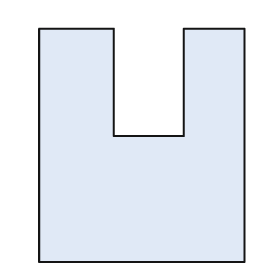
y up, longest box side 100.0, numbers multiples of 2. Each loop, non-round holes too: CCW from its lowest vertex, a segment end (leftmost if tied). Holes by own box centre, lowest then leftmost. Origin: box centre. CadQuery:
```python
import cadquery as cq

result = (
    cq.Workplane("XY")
    .moveTo(-44.0, -50.0)
    .lineTo(44.0, -50.0)
    .lineTo(44.0, 50.0)
    .lineTo(18.0, 50.0)
    .lineTo(18.0, 4.0)
    .lineTo(-12.0, 4.0)
    .lineTo(-12.0, 50.0)
    .lineTo(-44.0, 50.0)
    .close()
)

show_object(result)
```